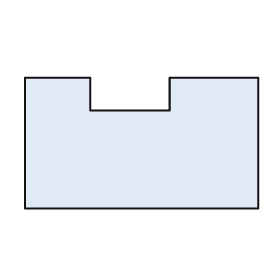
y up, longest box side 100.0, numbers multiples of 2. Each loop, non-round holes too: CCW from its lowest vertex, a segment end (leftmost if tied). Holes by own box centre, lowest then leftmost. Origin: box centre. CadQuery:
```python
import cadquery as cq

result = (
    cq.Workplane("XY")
    .moveTo(-50.0, -28.0)
    .lineTo(50.0, -28.0)
    .lineTo(50.0, 28.0)
    .lineTo(12.0, 28.0)
    .lineTo(12.0, 14.0)
    .lineTo(-22.0, 14.0)
    .lineTo(-22.0, 28.0)
    .lineTo(-50.0, 28.0)
    .close()
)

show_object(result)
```